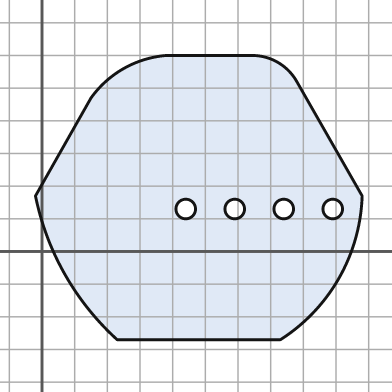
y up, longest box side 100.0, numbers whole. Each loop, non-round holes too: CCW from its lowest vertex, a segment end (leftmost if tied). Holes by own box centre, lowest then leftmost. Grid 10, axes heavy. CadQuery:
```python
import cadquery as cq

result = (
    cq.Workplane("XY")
    .moveTo(23.0, -27.0)
    .lineTo(73.0, -27.0)
    .threePointArc((91.0, -8.0), (98.0, 17.0))
    .lineTo(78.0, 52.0)
    .threePointArc((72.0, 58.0), (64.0, 60.0))
    .lineTo(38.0, 60.0)
    .threePointArc((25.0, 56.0), (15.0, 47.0))
    .lineTo(-2.0, 17.0)
    .threePointArc((7.0, -7.0), (23.0, -27.0))
    .close()
    .moveTo(44.0, 13.0)
    .circle(3.0)
    .moveTo(59.0, 13.0)
    .circle(3.0)
    .moveTo(74.0, 13.0)
    .circle(3.0)
    .moveTo(89.0, 13.0)
    .circle(3.0)
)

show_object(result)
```